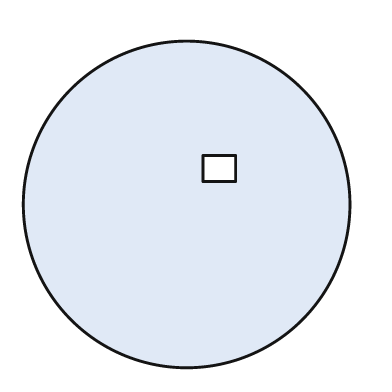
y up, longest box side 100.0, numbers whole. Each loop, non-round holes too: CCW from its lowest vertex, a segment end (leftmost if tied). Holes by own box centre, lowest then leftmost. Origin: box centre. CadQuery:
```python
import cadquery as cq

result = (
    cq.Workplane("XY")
    .moveTo(0.0, 0.0)
    .circle(50.0)
    .moveTo(5.0, 7.0)
    .lineTo(15.0, 7.0)
    .lineTo(15.0, 15.0)
    .lineTo(5.0, 15.0)
    .close()
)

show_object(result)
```